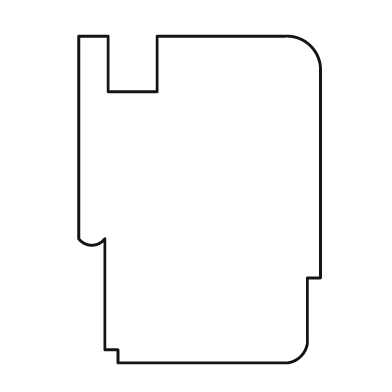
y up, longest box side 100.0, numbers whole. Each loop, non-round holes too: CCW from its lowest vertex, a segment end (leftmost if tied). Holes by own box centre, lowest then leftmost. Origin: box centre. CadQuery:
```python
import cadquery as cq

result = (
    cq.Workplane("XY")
    .moveTo(-25.0, -50.0)
    .lineTo(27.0, -50.0)
    .threePointArc((31.0, -48.0), (33.0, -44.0))
    .lineTo(33.0, -24.0)
    .lineTo(37.0, -24.0)
    .lineTo(37.0, 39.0)
    .threePointArc((34.0, 47.0), (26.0, 50.0))
    .lineTo(-13.0, 50.0)
    .lineTo(-13.0, 33.0)
    .lineTo(-28.0, 33.0)
    .lineTo(-28.0, 50.0)
    .lineTo(-37.0, 50.0)
    .lineTo(-37.0, -12.0)
    .threePointArc((-33.0, -14.0), (-29.0, -12.0))
    .lineTo(-29.0, -46.0)
    .lineTo(-25.0, -46.0)
    .close()
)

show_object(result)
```